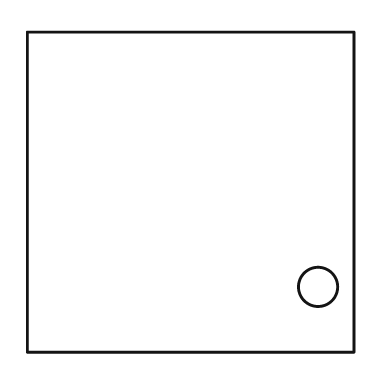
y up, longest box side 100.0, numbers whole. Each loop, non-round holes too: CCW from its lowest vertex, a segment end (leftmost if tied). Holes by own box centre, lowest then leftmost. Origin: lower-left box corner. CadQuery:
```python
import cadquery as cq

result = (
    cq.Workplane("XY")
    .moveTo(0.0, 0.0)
    .lineTo(100.0, 0.0)
    .lineTo(100.0, 98.0)
    .lineTo(0.0, 98.0)
    .close()
    .moveTo(89.0, 20.0)
    .circle(6.0)
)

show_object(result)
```